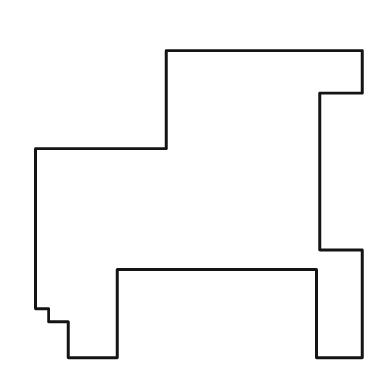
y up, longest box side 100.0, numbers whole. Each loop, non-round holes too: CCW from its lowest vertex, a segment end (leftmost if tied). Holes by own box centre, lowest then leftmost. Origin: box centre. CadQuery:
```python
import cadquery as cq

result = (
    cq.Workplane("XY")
    .moveTo(-40.0, -47.0)
    .lineTo(-25.0, -47.0)
    .lineTo(-25.0, -20.0)
    .lineTo(36.0, -20.0)
    .lineTo(36.0, -47.0)
    .lineTo(50.0, -47.0)
    .lineTo(50.0, -14.0)
    .lineTo(37.0, -14.0)
    .lineTo(37.0, 34.0)
    .lineTo(50.0, 34.0)
    .lineTo(50.0, 47.0)
    .lineTo(-10.0, 47.0)
    .lineTo(-10.0, 17.0)
    .lineTo(-50.0, 17.0)
    .lineTo(-50.0, -32.0)
    .lineTo(-46.0, -32.0)
    .lineTo(-46.0, -36.0)
    .lineTo(-40.0, -36.0)
    .close()
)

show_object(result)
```